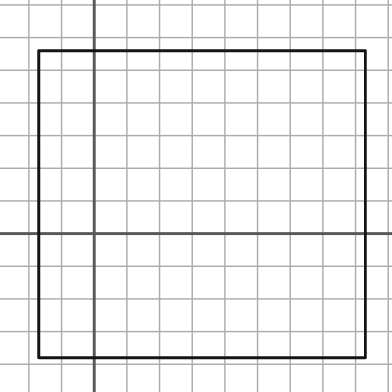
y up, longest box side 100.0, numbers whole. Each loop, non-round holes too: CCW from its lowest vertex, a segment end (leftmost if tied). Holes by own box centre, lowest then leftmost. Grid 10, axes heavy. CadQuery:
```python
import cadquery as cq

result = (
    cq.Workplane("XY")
    .moveTo(-17.0, -38.0)
    .lineTo(83.0, -38.0)
    .lineTo(83.0, 56.0)
    .lineTo(-17.0, 56.0)
    .close()
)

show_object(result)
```